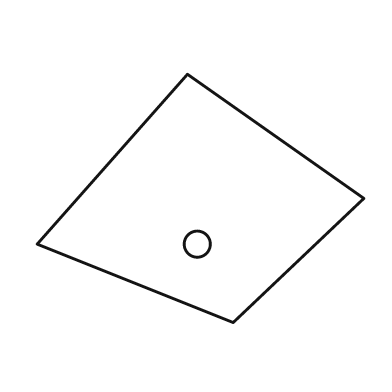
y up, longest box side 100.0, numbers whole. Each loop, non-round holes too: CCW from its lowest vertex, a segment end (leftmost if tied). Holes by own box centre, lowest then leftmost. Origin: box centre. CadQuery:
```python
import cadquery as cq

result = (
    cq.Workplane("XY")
    .moveTo(10.0, -38.0)
    .lineTo(50.0, 0.0)
    .lineTo(-4.0, 38.0)
    .lineTo(-50.0, -14.0)
    .close()
    .moveTo(-1.0, -14.0)
    .circle(4.0)
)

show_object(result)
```